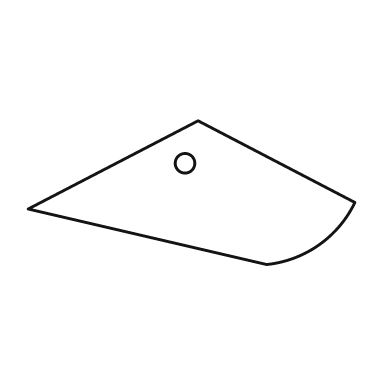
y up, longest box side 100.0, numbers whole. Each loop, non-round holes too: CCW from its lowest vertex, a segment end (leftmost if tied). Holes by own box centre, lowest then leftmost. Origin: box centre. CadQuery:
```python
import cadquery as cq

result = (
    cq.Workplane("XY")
    .moveTo(23.0, -22.0)
    .threePointArc((39.0, -16.0), (50.0, -3.0))
    .lineTo(2.0, 22.0)
    .lineTo(-50.0, -5.0)
    .close()
    .moveTo(-2.0, 9.0)
    .circle(3.0)
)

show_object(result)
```